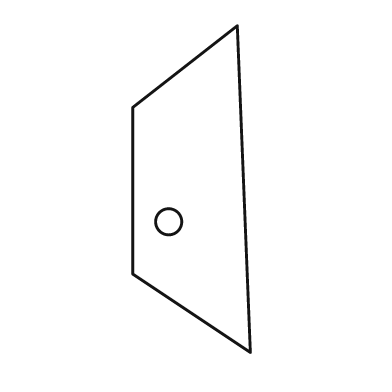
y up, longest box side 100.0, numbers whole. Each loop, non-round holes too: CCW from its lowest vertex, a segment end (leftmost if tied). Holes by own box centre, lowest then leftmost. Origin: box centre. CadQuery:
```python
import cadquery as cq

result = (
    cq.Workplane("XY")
    .moveTo(18.0, -50.0)
    .lineTo(14.0, 50.0)
    .lineTo(-18.0, 25.0)
    .lineTo(-18.0, -26.0)
    .close()
    .moveTo(-7.0, -10.0)
    .circle(4.0)
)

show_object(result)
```